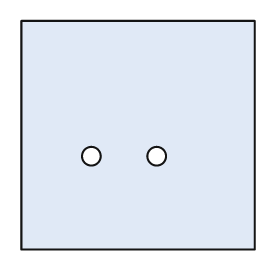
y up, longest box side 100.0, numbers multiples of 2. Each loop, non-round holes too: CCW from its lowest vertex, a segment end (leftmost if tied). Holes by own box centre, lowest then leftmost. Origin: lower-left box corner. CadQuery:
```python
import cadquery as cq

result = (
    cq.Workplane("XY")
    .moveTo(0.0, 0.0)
    .lineTo(100.0, 0.0)
    .lineTo(100.0, 98.0)
    .lineTo(0.0, 98.0)
    .close()
    .moveTo(30.0, 40.0)
    .circle(4.0)
    .moveTo(58.0, 40.0)
    .circle(4.0)
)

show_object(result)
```